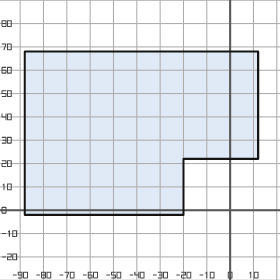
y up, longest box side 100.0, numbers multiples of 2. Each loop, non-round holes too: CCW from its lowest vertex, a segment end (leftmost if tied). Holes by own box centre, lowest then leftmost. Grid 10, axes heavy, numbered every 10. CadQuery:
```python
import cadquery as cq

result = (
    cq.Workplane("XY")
    .moveTo(-88.0, -2.0)
    .lineTo(-20.0, -2.0)
    .lineTo(-20.0, 22.0)
    .lineTo(12.0, 22.0)
    .lineTo(12.0, 68.0)
    .lineTo(-88.0, 68.0)
    .close()
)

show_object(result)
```